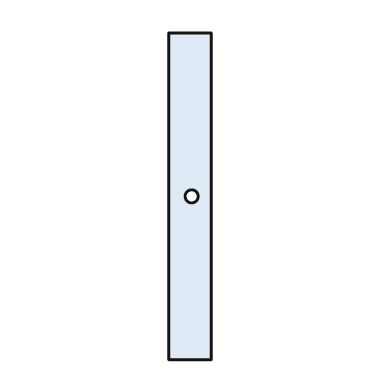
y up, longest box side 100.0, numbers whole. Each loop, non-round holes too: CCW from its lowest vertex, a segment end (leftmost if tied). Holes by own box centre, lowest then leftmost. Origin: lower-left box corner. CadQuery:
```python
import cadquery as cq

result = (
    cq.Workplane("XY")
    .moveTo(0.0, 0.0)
    .lineTo(13.0, 0.0)
    .lineTo(13.0, 100.0)
    .lineTo(0.0, 100.0)
    .close()
    .moveTo(7.0, 50.0)
    .circle(2.0)
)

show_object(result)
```